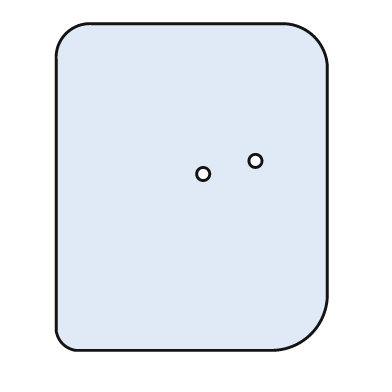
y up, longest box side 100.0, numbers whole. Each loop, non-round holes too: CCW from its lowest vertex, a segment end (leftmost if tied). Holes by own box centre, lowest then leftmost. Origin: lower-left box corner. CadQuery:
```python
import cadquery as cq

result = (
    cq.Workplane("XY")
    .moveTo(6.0, 0.0)
    .lineTo(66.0, 0.0)
    .threePointArc((78.0, 5.0), (83.0, 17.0))
    .lineTo(83.0, 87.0)
    .threePointArc((79.0, 96.0), (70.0, 100.0))
    .lineTo(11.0, 100.0)
    .threePointArc((3.0, 97.0), (0.0, 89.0))
    .lineTo(0.0, 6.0)
    .threePointArc((2.0, 2.0), (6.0, 0.0))
    .close()
    .moveTo(45.0, 54.0)
    .circle(2.0)
    .moveTo(61.0, 58.0)
    .circle(2.0)
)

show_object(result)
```